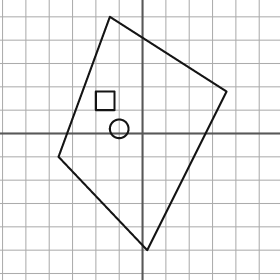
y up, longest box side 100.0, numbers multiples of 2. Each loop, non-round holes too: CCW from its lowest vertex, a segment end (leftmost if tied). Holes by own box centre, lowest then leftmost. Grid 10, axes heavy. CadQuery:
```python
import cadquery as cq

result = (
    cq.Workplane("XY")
    .moveTo(2.0, -50.0)
    .lineTo(36.0, 18.0)
    .lineTo(-14.0, 50.0)
    .lineTo(-36.0, -10.0)
    .close()
    .moveTo(-10.0, 2.0)
    .circle(4.0)
    .moveTo(-20.0, 10.0)
    .lineTo(-12.0, 10.0)
    .lineTo(-12.0, 18.0)
    .lineTo(-20.0, 18.0)
    .close()
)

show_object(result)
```